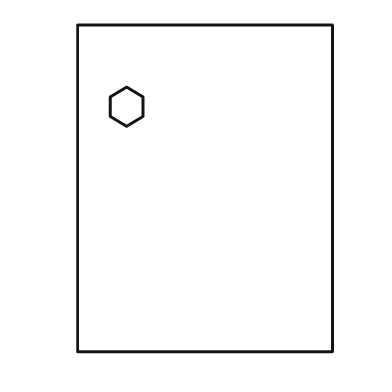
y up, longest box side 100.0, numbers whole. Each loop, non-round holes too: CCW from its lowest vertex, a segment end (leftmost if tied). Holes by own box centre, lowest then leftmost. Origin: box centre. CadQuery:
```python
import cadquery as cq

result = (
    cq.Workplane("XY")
    .moveTo(-39.0, -50.0)
    .lineTo(39.0, -50.0)
    .lineTo(39.0, 50.0)
    .lineTo(-39.0, 50.0)
    .close()
    .moveTo(-24.0, 19.0)
    .lineTo(-19.0, 22.0)
    .lineTo(-19.0, 28.0)
    .lineTo(-24.0, 31.0)
    .lineTo(-29.0, 28.0)
    .lineTo(-29.0, 22.0)
    .close()
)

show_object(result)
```